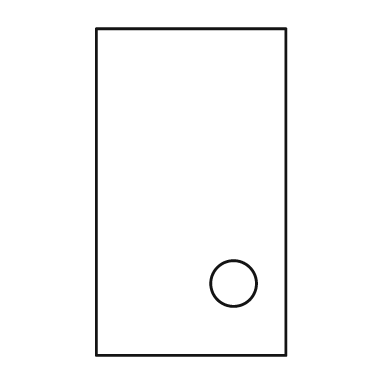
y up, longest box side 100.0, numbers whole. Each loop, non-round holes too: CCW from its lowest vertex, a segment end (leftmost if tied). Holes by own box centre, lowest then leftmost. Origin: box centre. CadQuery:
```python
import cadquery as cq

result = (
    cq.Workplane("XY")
    .moveTo(-29.0, -50.0)
    .lineTo(29.0, -50.0)
    .lineTo(29.0, 50.0)
    .lineTo(-29.0, 50.0)
    .close()
    .moveTo(13.0, -28.0)
    .circle(7.0)
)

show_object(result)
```